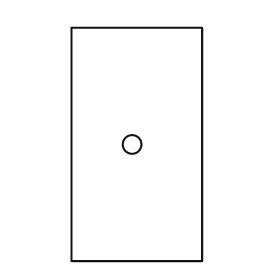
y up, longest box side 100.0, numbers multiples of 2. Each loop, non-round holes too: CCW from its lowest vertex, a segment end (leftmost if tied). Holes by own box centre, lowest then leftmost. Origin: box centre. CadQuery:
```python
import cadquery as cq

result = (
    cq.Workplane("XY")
    .moveTo(-28.0, -50.0)
    .lineTo(28.0, -50.0)
    .lineTo(28.0, 50.0)
    .lineTo(-28.0, 50.0)
    .close()
    .moveTo(-2.0, 0.0)
    .circle(4.0)
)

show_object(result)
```